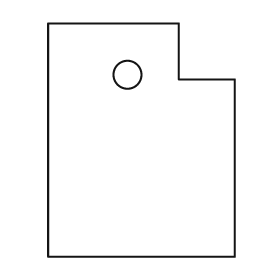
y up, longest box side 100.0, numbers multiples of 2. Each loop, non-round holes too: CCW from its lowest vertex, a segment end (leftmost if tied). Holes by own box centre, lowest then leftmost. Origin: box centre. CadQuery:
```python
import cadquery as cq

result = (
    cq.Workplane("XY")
    .moveTo(-40.0, -50.0)
    .lineTo(40.0, -50.0)
    .lineTo(40.0, 26.0)
    .lineTo(16.0, 26.0)
    .lineTo(16.0, 50.0)
    .lineTo(-40.0, 50.0)
    .close()
    .moveTo(-6.0, 28.0)
    .circle(6.0)
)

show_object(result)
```